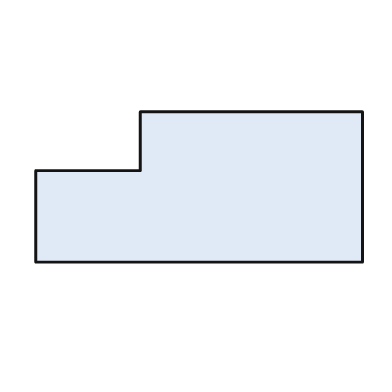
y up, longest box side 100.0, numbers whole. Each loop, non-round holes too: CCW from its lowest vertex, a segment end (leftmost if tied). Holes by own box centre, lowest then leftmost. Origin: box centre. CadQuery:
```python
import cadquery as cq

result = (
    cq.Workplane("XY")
    .moveTo(-50.0, -23.0)
    .lineTo(50.0, -23.0)
    .lineTo(50.0, 23.0)
    .lineTo(-18.0, 23.0)
    .lineTo(-18.0, 5.0)
    .lineTo(-50.0, 5.0)
    .close()
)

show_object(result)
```